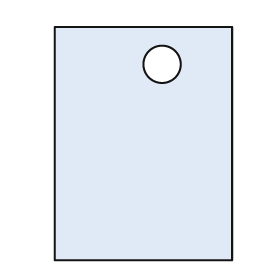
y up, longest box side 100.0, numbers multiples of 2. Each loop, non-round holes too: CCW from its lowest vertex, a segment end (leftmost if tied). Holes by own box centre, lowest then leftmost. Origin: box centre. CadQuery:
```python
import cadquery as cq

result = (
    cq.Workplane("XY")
    .moveTo(-38.0, -50.0)
    .lineTo(38.0, -50.0)
    .lineTo(38.0, 50.0)
    .lineTo(-38.0, 50.0)
    .close()
    .moveTo(8.0, 34.0)
    .circle(8.0)
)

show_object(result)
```